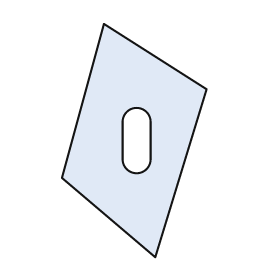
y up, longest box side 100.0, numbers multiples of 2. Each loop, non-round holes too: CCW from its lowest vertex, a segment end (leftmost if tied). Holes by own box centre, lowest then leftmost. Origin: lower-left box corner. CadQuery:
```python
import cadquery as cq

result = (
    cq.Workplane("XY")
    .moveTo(40.0, 0.0)
    .lineTo(62.0, 72.0)
    .lineTo(18.0, 100.0)
    .lineTo(0.0, 34.0)
    .close()
    .moveTo(26.0, 42.0)
    .threePointArc((32.0, 36.0), (38.0, 42.0))
    .lineTo(38.0, 58.0)
    .threePointArc((32.0, 64.0), (26.0, 58.0))
    .close()
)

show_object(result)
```